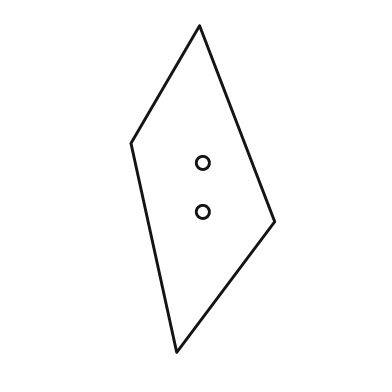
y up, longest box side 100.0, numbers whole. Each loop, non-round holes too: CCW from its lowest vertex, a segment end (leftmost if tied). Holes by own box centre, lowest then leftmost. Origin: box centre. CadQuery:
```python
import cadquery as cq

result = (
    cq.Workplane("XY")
    .moveTo(-8.0, -50.0)
    .lineTo(22.0, -10.0)
    .lineTo(-1.0, 50.0)
    .lineTo(-22.0, 14.0)
    .close()
    .moveTo(0.0, -7.0)
    .circle(2.0)
    .moveTo(0.0, 8.0)
    .circle(2.0)
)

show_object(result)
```